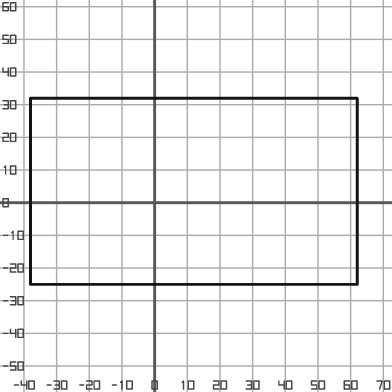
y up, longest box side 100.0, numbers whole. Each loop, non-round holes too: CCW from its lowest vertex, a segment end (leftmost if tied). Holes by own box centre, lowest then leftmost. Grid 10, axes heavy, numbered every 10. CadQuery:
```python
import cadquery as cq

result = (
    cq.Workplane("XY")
    .moveTo(-38.0, -25.0)
    .lineTo(62.0, -25.0)
    .lineTo(62.0, 32.0)
    .lineTo(-38.0, 32.0)
    .close()
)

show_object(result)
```